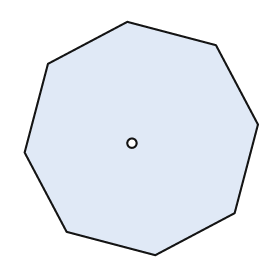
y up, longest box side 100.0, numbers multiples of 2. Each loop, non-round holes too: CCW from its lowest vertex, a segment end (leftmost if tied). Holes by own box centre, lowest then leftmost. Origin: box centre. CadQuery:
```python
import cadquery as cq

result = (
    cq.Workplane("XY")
    .moveTo(6.0, -50.0)
    .lineTo(40.0, -32.0)
    .lineTo(50.0, 6.0)
    .lineTo(32.0, 40.0)
    .lineTo(-6.0, 50.0)
    .lineTo(-40.0, 32.0)
    .lineTo(-50.0, -6.0)
    .lineTo(-32.0, -40.0)
    .close()
    .moveTo(-4.0, -2.0)
    .circle(2.0)
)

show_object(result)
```